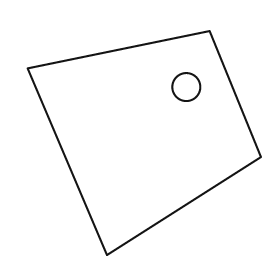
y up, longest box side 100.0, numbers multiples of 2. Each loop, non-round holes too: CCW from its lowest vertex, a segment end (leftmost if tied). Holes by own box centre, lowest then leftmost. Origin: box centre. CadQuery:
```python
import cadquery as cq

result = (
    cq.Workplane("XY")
    .moveTo(-16.0, -48.0)
    .lineTo(50.0, -6.0)
    .lineTo(28.0, 48.0)
    .lineTo(-50.0, 32.0)
    .close()
    .moveTo(18.0, 24.0)
    .circle(6.0)
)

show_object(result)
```